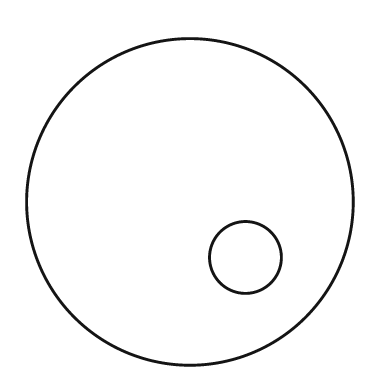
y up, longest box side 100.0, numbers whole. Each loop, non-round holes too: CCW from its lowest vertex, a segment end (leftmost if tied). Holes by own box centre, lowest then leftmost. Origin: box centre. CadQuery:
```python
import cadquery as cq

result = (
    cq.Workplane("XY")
    .moveTo(0.0, 0.0)
    .circle(50.0)
    .moveTo(17.0, -17.0)
    .circle(11.0)
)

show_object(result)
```